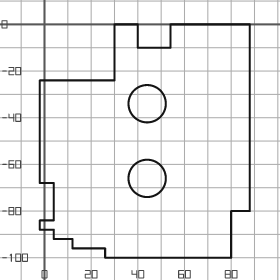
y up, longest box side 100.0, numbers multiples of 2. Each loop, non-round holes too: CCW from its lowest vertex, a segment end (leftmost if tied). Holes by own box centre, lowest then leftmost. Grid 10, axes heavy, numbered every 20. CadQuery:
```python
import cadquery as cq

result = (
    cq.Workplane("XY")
    .moveTo(26.0, -100.0)
    .lineTo(80.0, -100.0)
    .lineTo(80.0, -80.0)
    .lineTo(88.0, -80.0)
    .lineTo(88.0, 0.0)
    .lineTo(54.0, 0.0)
    .lineTo(54.0, -10.0)
    .lineTo(40.0, -10.0)
    .lineTo(40.0, 0.0)
    .lineTo(30.0, 0.0)
    .lineTo(30.0, -24.0)
    .lineTo(-2.0, -24.0)
    .lineTo(-2.0, -68.0)
    .lineTo(4.0, -68.0)
    .lineTo(4.0, -84.0)
    .lineTo(-2.0, -84.0)
    .lineTo(-2.0, -88.0)
    .lineTo(4.0, -88.0)
    .lineTo(4.0, -92.0)
    .lineTo(12.0, -92.0)
    .lineTo(12.0, -96.0)
    .lineTo(26.0, -96.0)
    .close()
    .moveTo(44.0, -66.0)
    .circle(8.0)
    .moveTo(44.0, -34.0)
    .circle(8.0)
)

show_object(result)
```